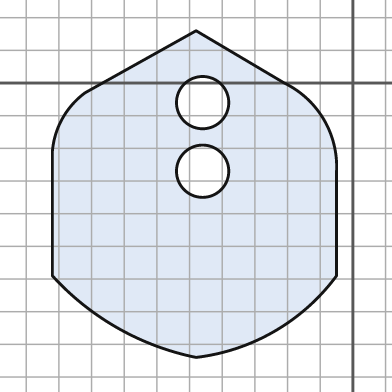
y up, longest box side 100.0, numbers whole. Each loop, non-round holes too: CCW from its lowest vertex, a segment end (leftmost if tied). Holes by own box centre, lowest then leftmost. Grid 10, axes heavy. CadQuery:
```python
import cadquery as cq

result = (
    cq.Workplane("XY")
    .moveTo(-48.0, -84.0)
    .threePointArc((-24.0, -76.0), (-5.0, -59.0))
    .lineTo(-5.0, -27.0)
    .threePointArc((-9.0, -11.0), (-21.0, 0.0))
    .lineTo(-48.0, 16.0)
    .lineTo(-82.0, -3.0)
    .threePointArc((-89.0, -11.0), (-92.0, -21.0))
    .lineTo(-92.0, -59.0)
    .threePointArc((-72.0, -75.0), (-48.0, -84.0))
    .close()
    .moveTo(-46.0, -27.0)
    .circle(8.0)
    .moveTo(-46.0, -6.0)
    .circle(8.0)
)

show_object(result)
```